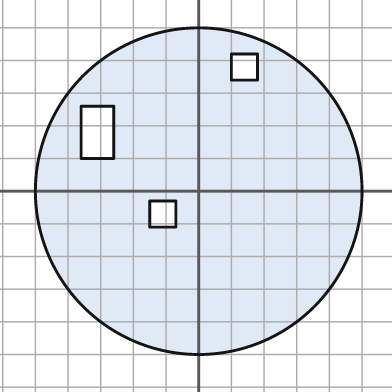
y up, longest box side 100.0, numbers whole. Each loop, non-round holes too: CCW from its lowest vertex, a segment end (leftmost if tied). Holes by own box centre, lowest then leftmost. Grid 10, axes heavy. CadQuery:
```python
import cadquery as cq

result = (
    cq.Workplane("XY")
    .moveTo(0.0, 0.0)
    .circle(50.0)
    .moveTo(-15.0, -11.0)
    .lineTo(-7.0, -11.0)
    .lineTo(-7.0, -3.0)
    .lineTo(-15.0, -3.0)
    .close()
    .moveTo(-36.0, 10.0)
    .lineTo(-26.0, 10.0)
    .lineTo(-26.0, 26.0)
    .lineTo(-36.0, 26.0)
    .close()
    .moveTo(10.0, 34.0)
    .lineTo(18.0, 34.0)
    .lineTo(18.0, 42.0)
    .lineTo(10.0, 42.0)
    .close()
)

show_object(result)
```